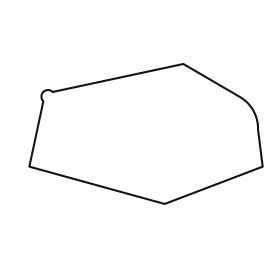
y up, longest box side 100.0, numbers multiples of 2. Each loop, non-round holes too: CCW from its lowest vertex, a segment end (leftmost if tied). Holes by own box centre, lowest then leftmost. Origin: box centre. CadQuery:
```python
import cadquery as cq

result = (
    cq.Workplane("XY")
    .moveTo(8.0, -30.0)
    .lineTo(50.0, -14.0)
    .lineTo(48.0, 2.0)
    .threePointArc((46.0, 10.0), (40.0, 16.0))
    .lineTo(16.0, 30.0)
    .lineTo(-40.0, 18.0)
    .threePointArc((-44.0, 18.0), (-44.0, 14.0))
    .lineTo(-50.0, -14.0)
    .close()
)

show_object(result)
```